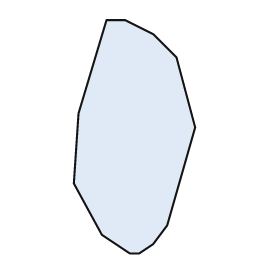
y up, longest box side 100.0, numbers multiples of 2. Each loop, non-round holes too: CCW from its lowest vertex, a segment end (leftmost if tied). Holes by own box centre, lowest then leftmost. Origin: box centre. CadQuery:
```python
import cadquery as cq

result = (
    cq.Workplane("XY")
    .moveTo(-2.0, -50.0)
    .lineTo(2.0, -50.0)
    .lineTo(8.0, -46.0)
    .lineTo(14.0, -38.0)
    .lineTo(26.0, 4.0)
    .lineTo(18.0, 34.0)
    .lineTo(8.0, 44.0)
    .lineTo(-4.0, 50.0)
    .lineTo(-12.0, 50.0)
    .lineTo(-24.0, 10.0)
    .lineTo(-26.0, -20.0)
    .lineTo(-14.0, -42.0)
    .close()
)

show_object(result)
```